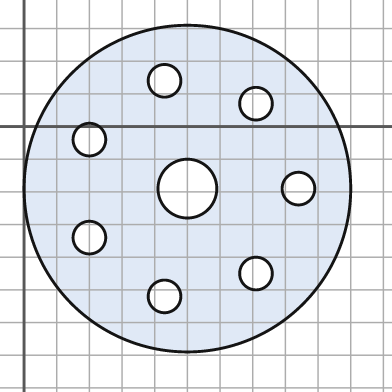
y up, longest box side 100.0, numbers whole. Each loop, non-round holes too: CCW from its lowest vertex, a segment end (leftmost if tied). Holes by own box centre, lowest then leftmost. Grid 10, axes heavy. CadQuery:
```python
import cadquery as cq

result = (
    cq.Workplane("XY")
    .moveTo(50.0, -19.0)
    .circle(50.0)
    .moveTo(43.0, -52.0)
    .circle(5.0)
    .moveTo(71.0, -45.0)
    .circle(5.0)
    .moveTo(20.0, -34.0)
    .circle(5.0)
    .moveTo(50.0, -19.0)
    .circle(9.0)
    .moveTo(84.0, -19.0)
    .circle(5.0)
    .moveTo(20.0, -4.0)
    .circle(5.0)
    .moveTo(71.0, 7.0)
    .circle(5.0)
    .moveTo(43.0, 14.0)
    .circle(5.0)
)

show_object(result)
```